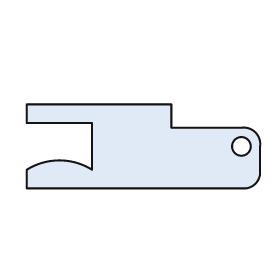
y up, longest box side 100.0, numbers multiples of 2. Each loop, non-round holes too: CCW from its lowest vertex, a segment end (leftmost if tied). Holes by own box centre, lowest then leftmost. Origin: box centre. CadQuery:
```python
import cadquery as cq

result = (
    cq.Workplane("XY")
    .moveTo(-50.0, -18.0)
    .lineTo(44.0, -18.0)
    .threePointArc((48.0, -16.0), (50.0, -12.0))
    .lineTo(50.0, 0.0)
    .threePointArc((48.0, 6.0), (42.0, 8.0))
    .lineTo(12.0, 8.0)
    .lineTo(12.0, 18.0)
    .lineTo(-50.0, 18.0)
    .lineTo(-50.0, 10.0)
    .lineTo(-22.0, 10.0)
    .lineTo(-22.0, -10.0)
    .threePointArc((-36.0, -6.0), (-50.0, -10.0))
    .close()
    .moveTo(42.0, 0.0)
    .circle(4.0)
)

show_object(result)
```